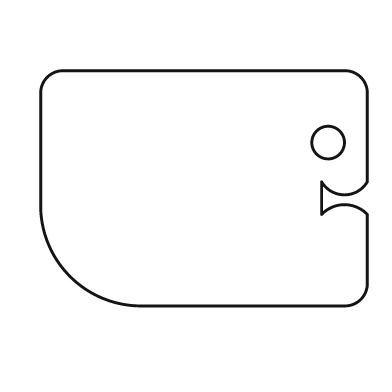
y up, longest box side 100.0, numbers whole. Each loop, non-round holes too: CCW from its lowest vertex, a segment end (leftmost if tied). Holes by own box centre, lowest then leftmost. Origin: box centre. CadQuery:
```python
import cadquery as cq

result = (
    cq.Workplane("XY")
    .moveTo(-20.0, -36.0)
    .lineTo(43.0, -36.0)
    .threePointArc((48.0, -34.0), (50.0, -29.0))
    .lineTo(50.0, -8.0)
    .threePointArc((43.0, -5.0), (36.0, -8.0))
    .lineTo(36.0, 2.0)
    .threePointArc((43.0, -2.0), (50.0, 2.0))
    .lineTo(50.0, 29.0)
    .threePointArc((48.0, 34.0), (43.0, 36.0))
    .lineTo(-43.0, 36.0)
    .threePointArc((-48.0, 34.0), (-50.0, 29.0))
    .lineTo(-50.0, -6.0)
    .threePointArc((-41.0, -27.0), (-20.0, -36.0))
    .close()
    .moveTo(38.0, 14.0)
    .circle(5.0)
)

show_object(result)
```